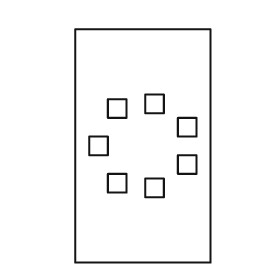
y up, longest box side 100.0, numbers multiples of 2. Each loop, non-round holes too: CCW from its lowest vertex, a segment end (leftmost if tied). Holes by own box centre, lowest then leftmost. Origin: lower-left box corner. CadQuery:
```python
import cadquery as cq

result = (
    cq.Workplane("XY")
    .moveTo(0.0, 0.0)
    .lineTo(58.0, 0.0)
    .lineTo(58.0, 100.0)
    .lineTo(0.0, 100.0)
    .close()
    .moveTo(30.0, 28.0)
    .lineTo(38.0, 28.0)
    .lineTo(38.0, 36.0)
    .lineTo(30.0, 36.0)
    .close()
    .moveTo(14.0, 30.0)
    .lineTo(22.0, 30.0)
    .lineTo(22.0, 38.0)
    .lineTo(14.0, 38.0)
    .close()
    .moveTo(44.0, 38.0)
    .lineTo(52.0, 38.0)
    .lineTo(52.0, 46.0)
    .lineTo(44.0, 46.0)
    .close()
    .moveTo(6.0, 46.0)
    .lineTo(14.0, 46.0)
    .lineTo(14.0, 54.0)
    .lineTo(6.0, 54.0)
    .close()
    .moveTo(44.0, 54.0)
    .lineTo(52.0, 54.0)
    .lineTo(52.0, 62.0)
    .lineTo(44.0, 62.0)
    .close()
    .moveTo(14.0, 62.0)
    .lineTo(22.0, 62.0)
    .lineTo(22.0, 70.0)
    .lineTo(14.0, 70.0)
    .close()
    .moveTo(30.0, 64.0)
    .lineTo(38.0, 64.0)
    .lineTo(38.0, 72.0)
    .lineTo(30.0, 72.0)
    .close()
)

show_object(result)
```